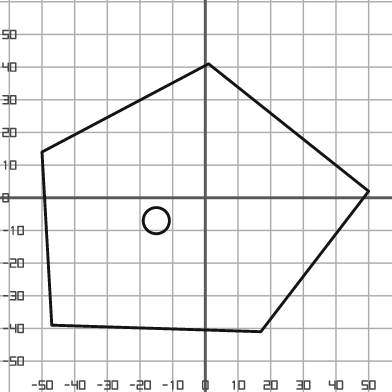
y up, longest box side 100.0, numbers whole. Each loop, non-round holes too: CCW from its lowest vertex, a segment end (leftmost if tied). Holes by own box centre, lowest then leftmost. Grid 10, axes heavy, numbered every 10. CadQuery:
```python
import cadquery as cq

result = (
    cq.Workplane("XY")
    .moveTo(17.0, -41.0)
    .lineTo(50.0, 2.0)
    .lineTo(1.0, 41.0)
    .lineTo(-50.0, 14.0)
    .lineTo(-47.0, -39.0)
    .close()
    .moveTo(-15.0, -7.0)
    .circle(4.0)
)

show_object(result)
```